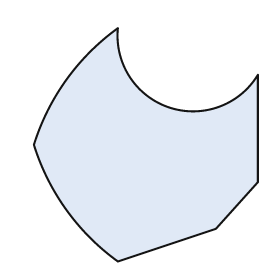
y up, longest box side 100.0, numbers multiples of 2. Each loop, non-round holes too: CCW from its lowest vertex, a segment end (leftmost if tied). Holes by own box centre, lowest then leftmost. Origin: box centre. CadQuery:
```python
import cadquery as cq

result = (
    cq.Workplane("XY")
    .moveTo(-12.0, -50.0)
    .lineTo(30.0, -36.0)
    .lineTo(48.0, -16.0)
    .lineTo(48.0, 30.0)
    .threePointArc((10.0, 16.0), (-12.0, 50.0))
    .threePointArc((-34.0, 28.0), (-48.0, 0.0))
    .threePointArc((-34.0, -28.0), (-12.0, -50.0))
    .close()
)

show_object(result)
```